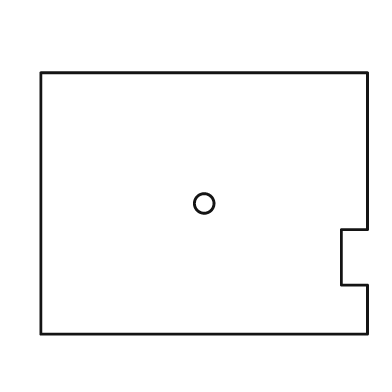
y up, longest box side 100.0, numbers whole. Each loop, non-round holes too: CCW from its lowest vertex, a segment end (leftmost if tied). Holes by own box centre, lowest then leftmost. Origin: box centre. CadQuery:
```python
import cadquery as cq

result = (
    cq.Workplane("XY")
    .moveTo(-50.0, -40.0)
    .lineTo(50.0, -40.0)
    .lineTo(50.0, -25.0)
    .lineTo(42.0, -25.0)
    .lineTo(42.0, -8.0)
    .lineTo(50.0, -8.0)
    .lineTo(50.0, 40.0)
    .lineTo(-50.0, 40.0)
    .close()
    .moveTo(0.0, 0.0)
    .circle(3.0)
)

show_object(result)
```